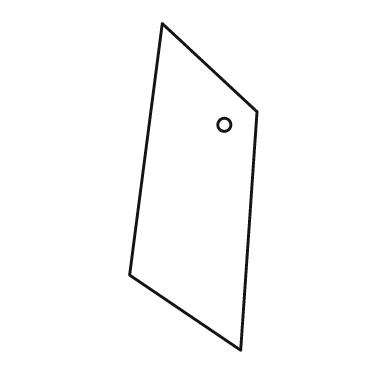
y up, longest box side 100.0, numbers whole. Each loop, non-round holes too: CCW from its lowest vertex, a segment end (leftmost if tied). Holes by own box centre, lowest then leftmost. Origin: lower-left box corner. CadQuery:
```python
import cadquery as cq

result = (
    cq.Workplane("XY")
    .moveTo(34.0, 0.0)
    .lineTo(39.0, 73.0)
    .lineTo(10.0, 100.0)
    .lineTo(0.0, 23.0)
    .close()
    .moveTo(29.0, 69.0)
    .circle(2.0)
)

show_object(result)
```